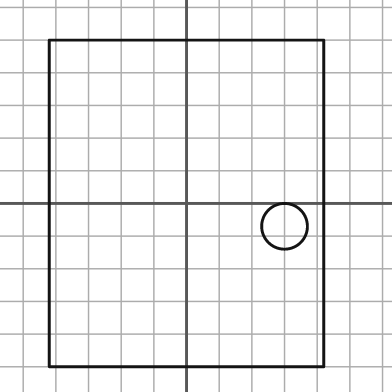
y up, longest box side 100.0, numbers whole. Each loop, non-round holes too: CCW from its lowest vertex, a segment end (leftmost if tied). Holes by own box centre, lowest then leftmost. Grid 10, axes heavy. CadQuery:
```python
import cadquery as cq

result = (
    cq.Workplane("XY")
    .moveTo(-42.0, -50.0)
    .lineTo(42.0, -50.0)
    .lineTo(42.0, 50.0)
    .lineTo(-42.0, 50.0)
    .close()
    .moveTo(30.0, -7.0)
    .circle(7.0)
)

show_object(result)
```